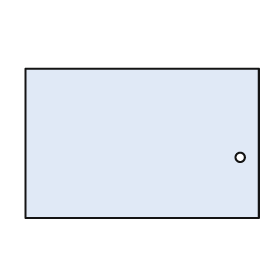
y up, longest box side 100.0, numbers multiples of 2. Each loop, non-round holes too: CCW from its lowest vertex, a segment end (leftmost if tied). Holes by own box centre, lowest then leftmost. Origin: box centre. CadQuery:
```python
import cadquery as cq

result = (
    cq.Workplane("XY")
    .moveTo(-50.0, -32.0)
    .lineTo(50.0, -32.0)
    .lineTo(50.0, 32.0)
    .lineTo(-50.0, 32.0)
    .close()
    .moveTo(42.0, -6.0)
    .circle(2.0)
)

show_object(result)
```